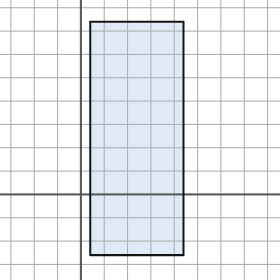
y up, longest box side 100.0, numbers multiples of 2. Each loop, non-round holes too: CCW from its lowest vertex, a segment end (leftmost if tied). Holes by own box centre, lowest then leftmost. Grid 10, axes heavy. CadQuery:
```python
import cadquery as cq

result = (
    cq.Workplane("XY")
    .moveTo(4.0, -26.0)
    .lineTo(44.0, -26.0)
    .lineTo(44.0, 74.0)
    .lineTo(4.0, 74.0)
    .close()
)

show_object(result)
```